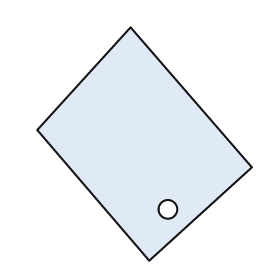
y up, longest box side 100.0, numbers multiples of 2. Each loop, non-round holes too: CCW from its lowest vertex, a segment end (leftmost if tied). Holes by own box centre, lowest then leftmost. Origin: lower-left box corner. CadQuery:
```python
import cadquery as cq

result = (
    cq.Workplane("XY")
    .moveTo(48.0, 0.0)
    .lineTo(92.0, 40.0)
    .lineTo(40.0, 100.0)
    .lineTo(0.0, 56.0)
    .close()
    .moveTo(56.0, 22.0)
    .circle(4.0)
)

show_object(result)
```